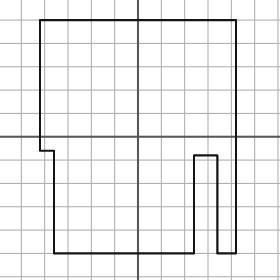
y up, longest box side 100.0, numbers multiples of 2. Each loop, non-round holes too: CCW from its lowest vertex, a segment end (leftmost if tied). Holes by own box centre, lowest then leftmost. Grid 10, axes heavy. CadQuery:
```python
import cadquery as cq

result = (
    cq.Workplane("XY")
    .moveTo(-36.0, -50.0)
    .lineTo(24.0, -50.0)
    .lineTo(24.0, -8.0)
    .lineTo(34.0, -8.0)
    .lineTo(34.0, -50.0)
    .lineTo(42.0, -50.0)
    .lineTo(42.0, 50.0)
    .lineTo(-42.0, 50.0)
    .lineTo(-42.0, -6.0)
    .lineTo(-36.0, -6.0)
    .close()
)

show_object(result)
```